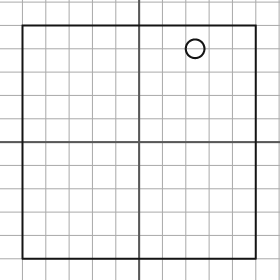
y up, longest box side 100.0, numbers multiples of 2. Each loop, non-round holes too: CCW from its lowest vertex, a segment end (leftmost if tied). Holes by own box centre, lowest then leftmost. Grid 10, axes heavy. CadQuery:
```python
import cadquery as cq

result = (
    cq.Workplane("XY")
    .moveTo(-50.0, -50.0)
    .lineTo(50.0, -50.0)
    .lineTo(50.0, 50.0)
    .lineTo(-50.0, 50.0)
    .close()
    .moveTo(24.0, 40.0)
    .circle(4.0)
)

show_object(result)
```